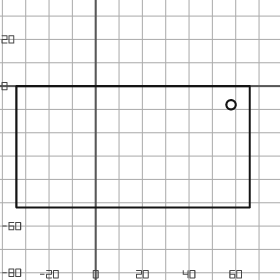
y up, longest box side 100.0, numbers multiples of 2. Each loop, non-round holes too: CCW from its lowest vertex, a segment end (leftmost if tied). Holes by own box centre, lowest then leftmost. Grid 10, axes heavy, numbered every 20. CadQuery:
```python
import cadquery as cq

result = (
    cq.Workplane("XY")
    .moveTo(-34.0, -52.0)
    .lineTo(66.0, -52.0)
    .lineTo(66.0, 0.0)
    .lineTo(-34.0, 0.0)
    .close()
    .moveTo(58.0, -8.0)
    .circle(2.0)
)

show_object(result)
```